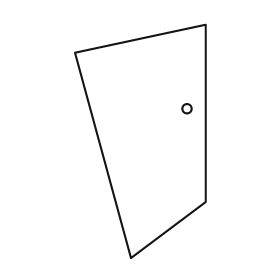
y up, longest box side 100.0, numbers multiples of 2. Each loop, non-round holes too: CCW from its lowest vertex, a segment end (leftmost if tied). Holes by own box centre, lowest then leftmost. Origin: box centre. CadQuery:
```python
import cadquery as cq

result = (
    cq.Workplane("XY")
    .moveTo(-4.0, -50.0)
    .lineTo(28.0, -26.0)
    .lineTo(28.0, 50.0)
    .lineTo(-28.0, 38.0)
    .close()
    .moveTo(20.0, 14.0)
    .circle(2.0)
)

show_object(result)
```